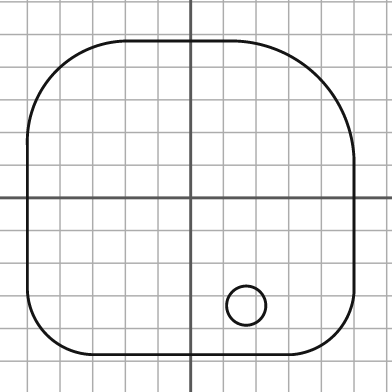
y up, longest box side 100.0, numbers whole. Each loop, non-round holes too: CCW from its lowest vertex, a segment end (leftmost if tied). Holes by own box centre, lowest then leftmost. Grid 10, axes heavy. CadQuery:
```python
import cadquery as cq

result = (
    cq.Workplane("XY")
    .moveTo(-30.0, -48.0)
    .lineTo(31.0, -48.0)
    .threePointArc((44.0, -42.0), (50.0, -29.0))
    .lineTo(50.0, 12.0)
    .threePointArc((39.0, 37.0), (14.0, 48.0))
    .lineTo(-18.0, 48.0)
    .threePointArc((-41.0, 39.0), (-50.0, 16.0))
    .lineTo(-50.0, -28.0)
    .threePointArc((-44.0, -42.0), (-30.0, -48.0))
    .close()
    .moveTo(17.0, -33.0)
    .circle(6.0)
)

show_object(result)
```